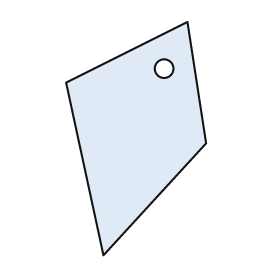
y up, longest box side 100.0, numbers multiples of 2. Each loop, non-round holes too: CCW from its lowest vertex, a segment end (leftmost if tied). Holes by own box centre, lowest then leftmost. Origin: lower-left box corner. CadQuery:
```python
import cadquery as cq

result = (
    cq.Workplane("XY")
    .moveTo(16.0, 0.0)
    .lineTo(60.0, 48.0)
    .lineTo(52.0, 100.0)
    .lineTo(0.0, 74.0)
    .close()
    .moveTo(42.0, 80.0)
    .circle(4.0)
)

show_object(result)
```